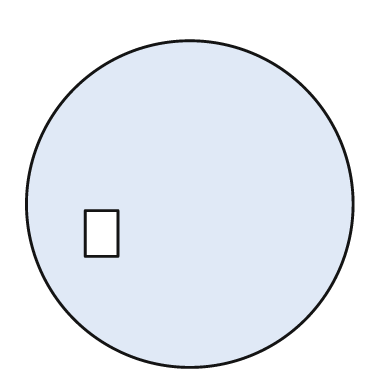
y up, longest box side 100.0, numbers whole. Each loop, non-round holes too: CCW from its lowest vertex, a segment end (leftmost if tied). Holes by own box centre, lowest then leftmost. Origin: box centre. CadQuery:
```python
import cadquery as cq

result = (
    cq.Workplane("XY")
    .moveTo(0.0, 0.0)
    .circle(50.0)
    .moveTo(-32.0, -16.0)
    .lineTo(-22.0, -16.0)
    .lineTo(-22.0, -2.0)
    .lineTo(-32.0, -2.0)
    .close()
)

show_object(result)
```